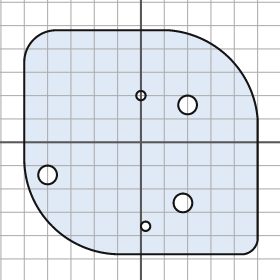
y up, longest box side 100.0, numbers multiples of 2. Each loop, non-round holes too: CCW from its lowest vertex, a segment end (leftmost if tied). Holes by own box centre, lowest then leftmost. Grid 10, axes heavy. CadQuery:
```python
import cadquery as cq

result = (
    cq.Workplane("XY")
    .moveTo(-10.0, -48.0)
    .lineTo(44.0, -48.0)
    .threePointArc((48.0, -46.0), (50.0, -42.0))
    .lineTo(50.0, 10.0)
    .threePointArc((38.0, 36.0), (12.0, 48.0))
    .lineTo(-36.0, 48.0)
    .threePointArc((-46.0, 44.0), (-50.0, 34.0))
    .lineTo(-50.0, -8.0)
    .threePointArc((-38.0, -36.0), (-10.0, -48.0))
    .close()
    .moveTo(2.0, -36.0)
    .circle(2.0)
    .moveTo(18.0, -26.0)
    .circle(4.0)
    .moveTo(-40.0, -14.0)
    .circle(4.0)
    .moveTo(20.0, 16.0)
    .circle(4.0)
    .moveTo(0.0, 20.0)
    .circle(2.0)
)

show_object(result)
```